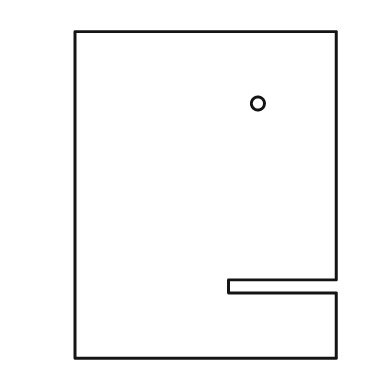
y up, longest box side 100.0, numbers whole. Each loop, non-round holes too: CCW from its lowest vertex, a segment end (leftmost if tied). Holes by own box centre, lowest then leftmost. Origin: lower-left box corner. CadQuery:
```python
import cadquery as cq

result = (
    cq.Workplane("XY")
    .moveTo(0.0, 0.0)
    .lineTo(80.0, 0.0)
    .lineTo(80.0, 20.0)
    .lineTo(47.0, 20.0)
    .lineTo(47.0, 24.0)
    .lineTo(80.0, 24.0)
    .lineTo(80.0, 100.0)
    .lineTo(0.0, 100.0)
    .close()
    .moveTo(56.0, 78.0)
    .circle(2.0)
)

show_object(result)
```